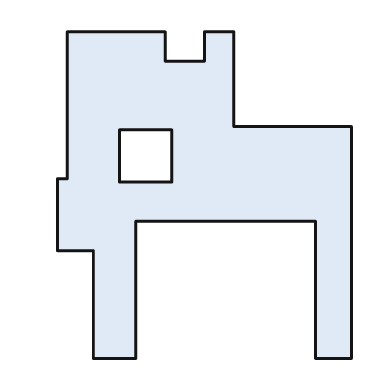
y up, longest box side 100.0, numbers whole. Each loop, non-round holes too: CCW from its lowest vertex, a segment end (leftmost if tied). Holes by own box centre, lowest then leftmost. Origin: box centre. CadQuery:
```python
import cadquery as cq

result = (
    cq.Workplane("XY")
    .moveTo(-34.0, -50.0)
    .lineTo(-21.0, -50.0)
    .lineTo(-21.0, -8.0)
    .lineTo(34.0, -8.0)
    .lineTo(34.0, -50.0)
    .lineTo(45.0, -50.0)
    .lineTo(45.0, 21.0)
    .lineTo(9.0, 21.0)
    .lineTo(9.0, 50.0)
    .lineTo(0.0, 50.0)
    .lineTo(0.0, 41.0)
    .lineTo(-12.0, 41.0)
    .lineTo(-12.0, 50.0)
    .lineTo(-42.0, 50.0)
    .lineTo(-42.0, 5.0)
    .lineTo(-45.0, 5.0)
    .lineTo(-45.0, -17.0)
    .lineTo(-34.0, -17.0)
    .close()
    .moveTo(-26.0, 4.0)
    .lineTo(-10.0, 4.0)
    .lineTo(-10.0, 20.0)
    .lineTo(-26.0, 20.0)
    .close()
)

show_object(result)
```